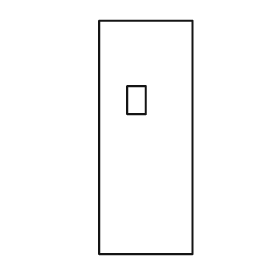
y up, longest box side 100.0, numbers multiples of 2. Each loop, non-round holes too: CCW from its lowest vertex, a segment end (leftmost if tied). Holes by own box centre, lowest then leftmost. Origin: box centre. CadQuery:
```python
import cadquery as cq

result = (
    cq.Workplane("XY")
    .moveTo(-20.0, -50.0)
    .lineTo(20.0, -50.0)
    .lineTo(20.0, 50.0)
    .lineTo(-20.0, 50.0)
    .close()
    .moveTo(-8.0, 10.0)
    .lineTo(0.0, 10.0)
    .lineTo(0.0, 22.0)
    .lineTo(-8.0, 22.0)
    .close()
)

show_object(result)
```